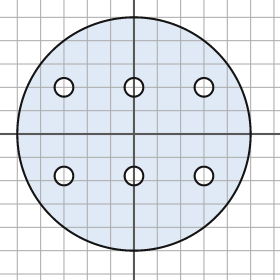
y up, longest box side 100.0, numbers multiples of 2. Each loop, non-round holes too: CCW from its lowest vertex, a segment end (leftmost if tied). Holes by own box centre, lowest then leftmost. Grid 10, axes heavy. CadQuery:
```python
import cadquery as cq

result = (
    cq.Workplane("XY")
    .moveTo(0.0, 0.0)
    .circle(50.0)
    .moveTo(-30.0, -18.0)
    .circle(4.0)
    .moveTo(0.0, -18.0)
    .circle(4.0)
    .moveTo(30.0, -18.0)
    .circle(4.0)
    .moveTo(-30.0, 20.0)
    .circle(4.0)
    .moveTo(0.0, 20.0)
    .circle(4.0)
    .moveTo(30.0, 20.0)
    .circle(4.0)
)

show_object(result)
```